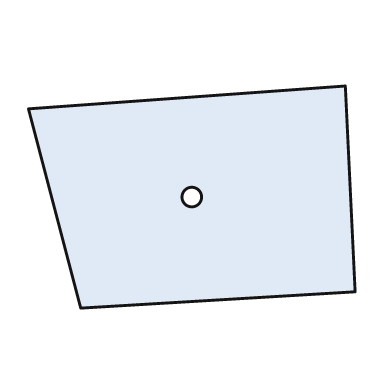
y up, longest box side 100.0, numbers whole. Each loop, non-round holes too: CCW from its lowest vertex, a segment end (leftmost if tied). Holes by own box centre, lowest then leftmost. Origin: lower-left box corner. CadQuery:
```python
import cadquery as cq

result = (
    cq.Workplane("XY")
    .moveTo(16.0, 0.0)
    .lineTo(100.0, 5.0)
    .lineTo(97.0, 68.0)
    .lineTo(0.0, 61.0)
    .close()
    .moveTo(50.0, 34.0)
    .circle(3.0)
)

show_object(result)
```